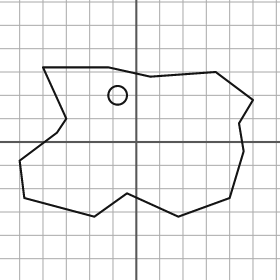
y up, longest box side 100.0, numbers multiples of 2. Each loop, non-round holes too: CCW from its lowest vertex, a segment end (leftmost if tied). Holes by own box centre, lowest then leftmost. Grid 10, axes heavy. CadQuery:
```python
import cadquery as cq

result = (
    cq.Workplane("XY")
    .moveTo(-18.0, -32.0)
    .lineTo(-4.0, -22.0)
    .lineTo(18.0, -32.0)
    .lineTo(40.0, -24.0)
    .lineTo(46.0, -4.0)
    .lineTo(44.0, 8.0)
    .lineTo(50.0, 18.0)
    .lineTo(34.0, 30.0)
    .lineTo(6.0, 28.0)
    .lineTo(-12.0, 32.0)
    .lineTo(-40.0, 32.0)
    .lineTo(-30.0, 10.0)
    .lineTo(-34.0, 4.0)
    .lineTo(-50.0, -8.0)
    .lineTo(-48.0, -24.0)
    .close()
    .moveTo(-8.0, 20.0)
    .circle(4.0)
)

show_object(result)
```